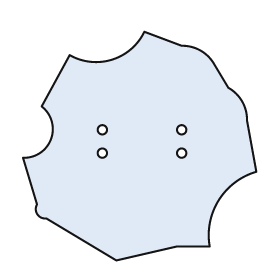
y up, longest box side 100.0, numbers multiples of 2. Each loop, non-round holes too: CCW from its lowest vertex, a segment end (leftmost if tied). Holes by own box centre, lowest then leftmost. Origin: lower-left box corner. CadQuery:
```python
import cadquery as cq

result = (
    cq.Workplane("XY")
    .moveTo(40.0, 0.0)
    .lineTo(66.0, 6.0)
    .lineTo(80.0, 6.0)
    .threePointArc((84.0, 26.0), (100.0, 38.0))
    .lineTo(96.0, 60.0)
    .threePointArc((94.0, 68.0), (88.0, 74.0))
    .lineTo(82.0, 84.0)
    .threePointArc((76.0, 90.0), (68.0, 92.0))
    .lineTo(52.0, 98.0)
    .threePointArc((38.0, 86.0), (20.0, 88.0))
    .lineTo(8.0, 66.0)
    .threePointArc((12.0, 52.0), (0.0, 44.0))
    .lineTo(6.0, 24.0)
    .threePointArc((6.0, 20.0), (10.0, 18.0))
    .close()
    .moveTo(34.0, 46.0)
    .circle(2.0)
    .moveTo(68.0, 46.0)
    .circle(2.0)
    .moveTo(34.0, 56.0)
    .circle(2.0)
    .moveTo(68.0, 56.0)
    .circle(2.0)
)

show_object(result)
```